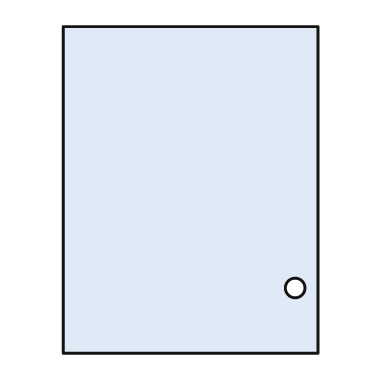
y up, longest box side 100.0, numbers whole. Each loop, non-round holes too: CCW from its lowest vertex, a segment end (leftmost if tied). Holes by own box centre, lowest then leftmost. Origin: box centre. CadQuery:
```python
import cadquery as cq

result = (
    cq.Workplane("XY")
    .moveTo(-39.0, -50.0)
    .lineTo(39.0, -50.0)
    .lineTo(39.0, 50.0)
    .lineTo(-39.0, 50.0)
    .close()
    .moveTo(32.0, -30.0)
    .circle(3.0)
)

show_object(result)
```